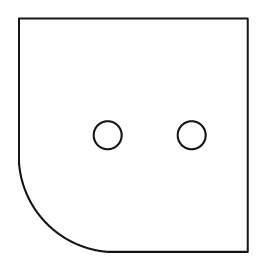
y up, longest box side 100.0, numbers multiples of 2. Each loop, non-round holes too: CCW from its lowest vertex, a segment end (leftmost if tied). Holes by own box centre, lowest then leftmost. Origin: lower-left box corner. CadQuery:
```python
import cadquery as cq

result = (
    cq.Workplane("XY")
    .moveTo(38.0, 0.0)
    .lineTo(98.0, 0.0)
    .lineTo(98.0, 100.0)
    .lineTo(0.0, 100.0)
    .lineTo(0.0, 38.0)
    .threePointArc((12.0, 12.0), (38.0, 0.0))
    .close()
    .moveTo(38.0, 50.0)
    .circle(6.0)
    .moveTo(74.0, 50.0)
    .circle(6.0)
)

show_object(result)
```